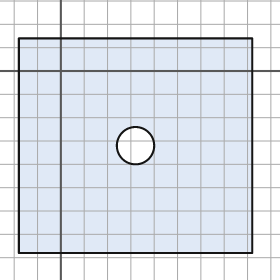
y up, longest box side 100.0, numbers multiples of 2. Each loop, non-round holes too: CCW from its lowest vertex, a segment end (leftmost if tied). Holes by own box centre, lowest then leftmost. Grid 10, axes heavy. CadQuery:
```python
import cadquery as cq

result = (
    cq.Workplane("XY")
    .moveTo(-18.0, -78.0)
    .lineTo(82.0, -78.0)
    .lineTo(82.0, 14.0)
    .lineTo(-18.0, 14.0)
    .close()
    .moveTo(32.0, -32.0)
    .circle(8.0)
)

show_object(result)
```